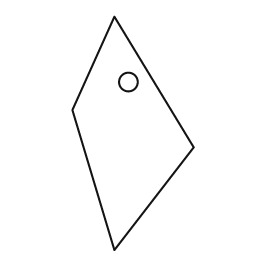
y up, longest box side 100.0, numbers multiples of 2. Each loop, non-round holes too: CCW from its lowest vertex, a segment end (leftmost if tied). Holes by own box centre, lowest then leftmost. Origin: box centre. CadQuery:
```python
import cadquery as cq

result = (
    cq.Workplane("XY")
    .moveTo(-8.0, -50.0)
    .lineTo(26.0, -6.0)
    .lineTo(-8.0, 50.0)
    .lineTo(-26.0, 10.0)
    .close()
    .moveTo(-2.0, 22.0)
    .circle(4.0)
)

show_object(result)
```